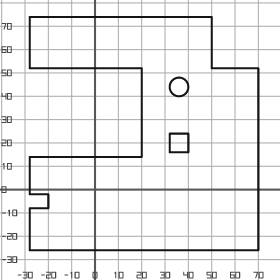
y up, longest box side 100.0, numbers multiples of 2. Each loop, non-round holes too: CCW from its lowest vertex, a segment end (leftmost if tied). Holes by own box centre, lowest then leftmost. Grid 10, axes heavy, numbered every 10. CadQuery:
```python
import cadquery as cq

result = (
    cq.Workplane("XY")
    .moveTo(-28.0, -26.0)
    .lineTo(70.0, -26.0)
    .lineTo(70.0, 52.0)
    .lineTo(50.0, 52.0)
    .lineTo(50.0, 74.0)
    .lineTo(-28.0, 74.0)
    .lineTo(-28.0, 52.0)
    .lineTo(20.0, 52.0)
    .lineTo(20.0, 14.0)
    .lineTo(-28.0, 14.0)
    .lineTo(-28.0, -2.0)
    .lineTo(-20.0, -2.0)
    .lineTo(-20.0, -8.0)
    .lineTo(-28.0, -8.0)
    .close()
    .moveTo(32.0, 16.0)
    .lineTo(40.0, 16.0)
    .lineTo(40.0, 24.0)
    .lineTo(32.0, 24.0)
    .close()
    .moveTo(36.0, 44.0)
    .circle(4.0)
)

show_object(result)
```